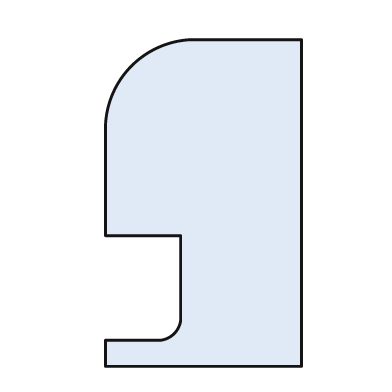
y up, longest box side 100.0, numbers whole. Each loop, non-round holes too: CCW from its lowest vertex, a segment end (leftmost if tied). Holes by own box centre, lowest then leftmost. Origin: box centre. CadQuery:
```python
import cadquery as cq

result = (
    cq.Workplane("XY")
    .moveTo(-30.0, -50.0)
    .lineTo(30.0, -50.0)
    .lineTo(30.0, 50.0)
    .lineTo(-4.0, 50.0)
    .threePointArc((-22.0, 42.0), (-30.0, 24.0))
    .lineTo(-30.0, -10.0)
    .lineTo(-7.0, -10.0)
    .lineTo(-7.0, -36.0)
    .threePointArc((-9.0, -40.0), (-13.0, -42.0))
    .lineTo(-30.0, -42.0)
    .close()
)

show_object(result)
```